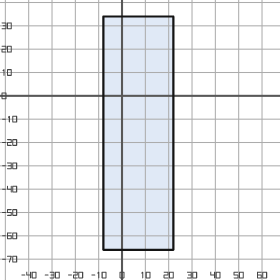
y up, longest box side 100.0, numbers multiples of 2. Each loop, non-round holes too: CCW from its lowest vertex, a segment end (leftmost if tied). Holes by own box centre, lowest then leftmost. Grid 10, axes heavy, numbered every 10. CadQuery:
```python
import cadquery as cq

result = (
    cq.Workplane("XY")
    .moveTo(-8.0, -66.0)
    .lineTo(22.0, -66.0)
    .lineTo(22.0, 34.0)
    .lineTo(-8.0, 34.0)
    .close()
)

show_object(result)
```